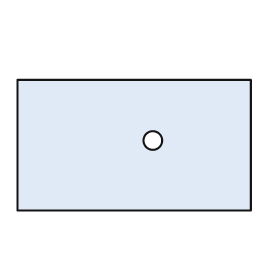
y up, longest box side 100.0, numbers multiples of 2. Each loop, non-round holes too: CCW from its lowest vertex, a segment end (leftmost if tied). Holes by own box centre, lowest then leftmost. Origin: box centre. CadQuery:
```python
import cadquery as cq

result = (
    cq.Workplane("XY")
    .moveTo(-50.0, -28.0)
    .lineTo(50.0, -28.0)
    .lineTo(50.0, 28.0)
    .lineTo(-50.0, 28.0)
    .close()
    .moveTo(8.0, 2.0)
    .circle(4.0)
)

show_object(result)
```